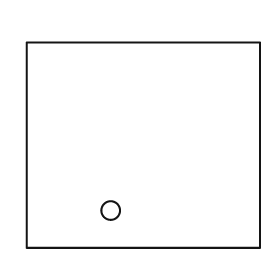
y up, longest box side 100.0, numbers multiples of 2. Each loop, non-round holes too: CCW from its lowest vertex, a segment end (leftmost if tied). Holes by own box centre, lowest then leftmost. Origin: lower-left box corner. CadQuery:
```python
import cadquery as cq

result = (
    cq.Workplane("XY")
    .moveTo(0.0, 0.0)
    .lineTo(100.0, 0.0)
    .lineTo(100.0, 88.0)
    .lineTo(0.0, 88.0)
    .close()
    .moveTo(36.0, 16.0)
    .circle(4.0)
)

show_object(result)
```